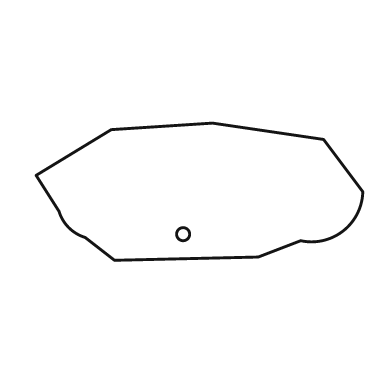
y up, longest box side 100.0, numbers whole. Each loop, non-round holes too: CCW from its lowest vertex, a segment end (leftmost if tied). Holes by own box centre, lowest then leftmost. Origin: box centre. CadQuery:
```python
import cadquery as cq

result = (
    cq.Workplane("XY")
    .moveTo(-26.0, -21.0)
    .lineTo(18.0, -20.0)
    .lineTo(31.0, -15.0)
    .threePointArc((44.0, -12.0), (50.0, 0.0))
    .lineTo(38.0, 16.0)
    .lineTo(4.0, 21.0)
    .lineTo(-27.0, 19.0)
    .lineTo(-50.0, 5.0)
    .lineTo(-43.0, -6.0)
    .threePointArc((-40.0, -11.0), (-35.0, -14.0))
    .close()
    .moveTo(-5.0, -13.0)
    .circle(2.0)
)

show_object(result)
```